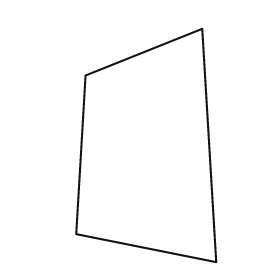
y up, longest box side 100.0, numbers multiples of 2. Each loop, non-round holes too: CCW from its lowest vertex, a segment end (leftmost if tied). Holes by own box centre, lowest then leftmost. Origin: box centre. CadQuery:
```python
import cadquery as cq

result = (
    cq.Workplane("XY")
    .moveTo(30.0, -50.0)
    .lineTo(24.0, 50.0)
    .lineTo(-26.0, 30.0)
    .lineTo(-30.0, -38.0)
    .close()
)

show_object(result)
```